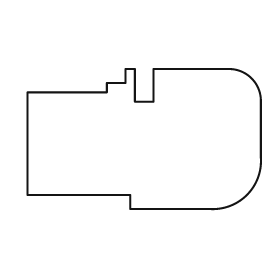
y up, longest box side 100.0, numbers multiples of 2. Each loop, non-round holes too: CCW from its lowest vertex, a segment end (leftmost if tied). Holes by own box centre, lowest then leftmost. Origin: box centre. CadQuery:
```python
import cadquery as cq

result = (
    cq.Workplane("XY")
    .moveTo(-6.0, -30.0)
    .lineTo(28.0, -30.0)
    .threePointArc((44.0, -24.0), (50.0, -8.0))
    .lineTo(50.0, 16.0)
    .threePointArc((46.0, 26.0), (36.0, 30.0))
    .lineTo(4.0, 30.0)
    .lineTo(4.0, 16.0)
    .lineTo(-4.0, 16.0)
    .lineTo(-4.0, 30.0)
    .lineTo(-8.0, 30.0)
    .lineTo(-8.0, 24.0)
    .lineTo(-16.0, 24.0)
    .lineTo(-16.0, 20.0)
    .lineTo(-50.0, 20.0)
    .lineTo(-50.0, -24.0)
    .lineTo(-6.0, -24.0)
    .close()
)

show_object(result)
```